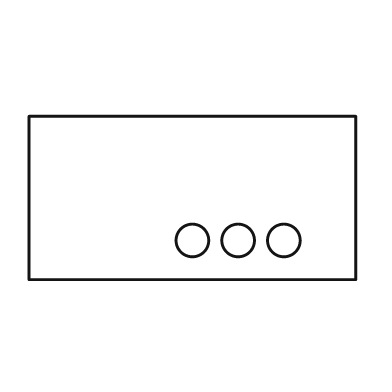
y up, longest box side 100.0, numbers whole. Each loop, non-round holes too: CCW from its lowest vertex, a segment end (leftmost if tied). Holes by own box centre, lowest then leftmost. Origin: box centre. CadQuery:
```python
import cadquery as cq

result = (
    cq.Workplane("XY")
    .moveTo(-50.0, -25.0)
    .lineTo(50.0, -25.0)
    .lineTo(50.0, 25.0)
    .lineTo(-50.0, 25.0)
    .close()
    .moveTo(0.0, -13.0)
    .circle(5.0)
    .moveTo(14.0, -13.0)
    .circle(5.0)
    .moveTo(28.0, -13.0)
    .circle(5.0)
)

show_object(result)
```